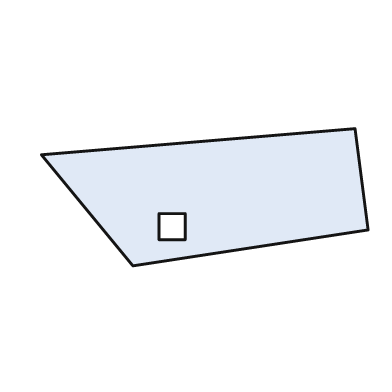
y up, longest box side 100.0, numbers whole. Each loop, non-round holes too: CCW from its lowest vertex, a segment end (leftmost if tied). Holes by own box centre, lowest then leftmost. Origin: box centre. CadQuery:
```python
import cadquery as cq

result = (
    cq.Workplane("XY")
    .moveTo(-22.0, -21.0)
    .lineTo(50.0, -10.0)
    .lineTo(46.0, 21.0)
    .lineTo(-50.0, 13.0)
    .close()
    .moveTo(-14.0, -13.0)
    .lineTo(-6.0, -13.0)
    .lineTo(-6.0, -5.0)
    .lineTo(-14.0, -5.0)
    .close()
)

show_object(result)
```